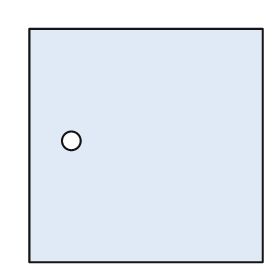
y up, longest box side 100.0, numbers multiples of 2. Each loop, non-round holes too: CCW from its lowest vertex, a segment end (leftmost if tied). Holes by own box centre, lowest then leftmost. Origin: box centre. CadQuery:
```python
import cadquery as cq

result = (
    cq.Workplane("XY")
    .moveTo(-50.0, -50.0)
    .lineTo(50.0, -50.0)
    .lineTo(50.0, 50.0)
    .lineTo(-50.0, 50.0)
    .close()
    .moveTo(-32.0, 2.0)
    .circle(4.0)
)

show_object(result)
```